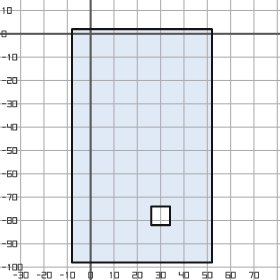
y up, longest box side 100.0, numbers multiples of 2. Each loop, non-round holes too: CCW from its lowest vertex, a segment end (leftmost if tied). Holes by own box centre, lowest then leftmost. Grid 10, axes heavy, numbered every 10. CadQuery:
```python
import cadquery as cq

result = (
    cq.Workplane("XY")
    .moveTo(-8.0, -98.0)
    .lineTo(52.0, -98.0)
    .lineTo(52.0, 2.0)
    .lineTo(-8.0, 2.0)
    .close()
    .moveTo(26.0, -82.0)
    .lineTo(34.0, -82.0)
    .lineTo(34.0, -74.0)
    .lineTo(26.0, -74.0)
    .close()
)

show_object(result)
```